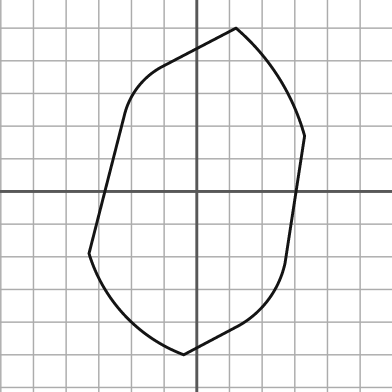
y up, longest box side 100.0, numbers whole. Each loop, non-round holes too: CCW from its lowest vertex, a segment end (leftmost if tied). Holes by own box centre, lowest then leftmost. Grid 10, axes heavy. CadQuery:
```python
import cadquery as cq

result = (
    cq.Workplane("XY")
    .moveTo(-4.0, -50.0)
    .lineTo(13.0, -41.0)
    .threePointArc((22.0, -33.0), (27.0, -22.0))
    .lineTo(33.0, 17.0)
    .threePointArc((25.0, 35.0), (12.0, 50.0))
    .lineTo(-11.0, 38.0)
    .threePointArc((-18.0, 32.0), (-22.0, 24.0))
    .lineTo(-33.0, -19.0)
    .threePointArc((-22.0, -38.0), (-4.0, -50.0))
    .close()
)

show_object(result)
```